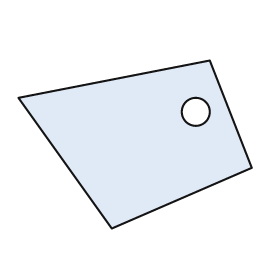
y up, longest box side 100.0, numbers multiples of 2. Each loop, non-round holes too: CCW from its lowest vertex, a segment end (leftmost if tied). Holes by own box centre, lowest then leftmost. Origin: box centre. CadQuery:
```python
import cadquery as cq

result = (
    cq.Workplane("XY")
    .moveTo(-10.0, -36.0)
    .lineTo(50.0, -10.0)
    .lineTo(32.0, 36.0)
    .lineTo(-50.0, 20.0)
    .close()
    .moveTo(26.0, 14.0)
    .circle(6.0)
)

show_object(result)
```